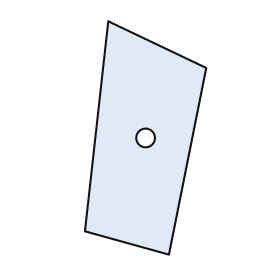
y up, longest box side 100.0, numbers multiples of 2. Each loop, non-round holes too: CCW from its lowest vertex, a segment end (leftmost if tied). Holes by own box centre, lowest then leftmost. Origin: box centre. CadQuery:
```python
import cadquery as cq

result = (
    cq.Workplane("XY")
    .moveTo(10.0, -50.0)
    .lineTo(26.0, 30.0)
    .lineTo(-16.0, 50.0)
    .lineTo(-26.0, -40.0)
    .close()
    .moveTo(0.0, 0.0)
    .circle(4.0)
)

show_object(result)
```